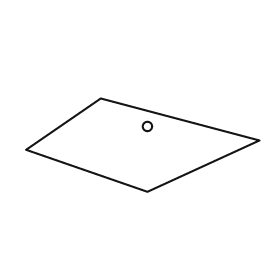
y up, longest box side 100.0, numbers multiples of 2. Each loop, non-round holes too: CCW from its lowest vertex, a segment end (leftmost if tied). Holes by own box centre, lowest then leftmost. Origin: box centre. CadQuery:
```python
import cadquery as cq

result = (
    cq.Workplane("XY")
    .moveTo(2.0, -20.0)
    .lineTo(50.0, 2.0)
    .lineTo(-18.0, 20.0)
    .lineTo(-50.0, -2.0)
    .close()
    .moveTo(2.0, 8.0)
    .circle(2.0)
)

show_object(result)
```